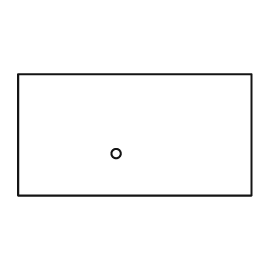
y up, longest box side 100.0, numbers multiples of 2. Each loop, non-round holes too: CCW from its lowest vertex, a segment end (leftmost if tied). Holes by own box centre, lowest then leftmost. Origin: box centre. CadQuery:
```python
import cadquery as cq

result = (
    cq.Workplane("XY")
    .moveTo(-50.0, -26.0)
    .lineTo(50.0, -26.0)
    .lineTo(50.0, 26.0)
    .lineTo(-50.0, 26.0)
    .close()
    .moveTo(-8.0, -8.0)
    .circle(2.0)
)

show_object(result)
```